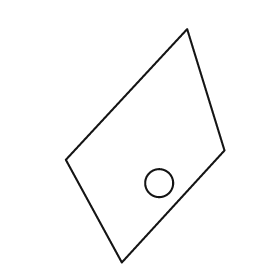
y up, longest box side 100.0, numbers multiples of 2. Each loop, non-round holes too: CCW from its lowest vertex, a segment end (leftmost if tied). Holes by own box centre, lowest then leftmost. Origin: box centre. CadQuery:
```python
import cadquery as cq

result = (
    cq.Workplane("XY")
    .moveTo(-10.0, -50.0)
    .lineTo(34.0, -2.0)
    .lineTo(18.0, 50.0)
    .lineTo(-34.0, -6.0)
    .close()
    .moveTo(6.0, -16.0)
    .circle(6.0)
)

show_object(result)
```